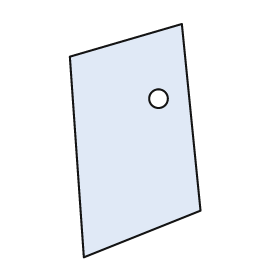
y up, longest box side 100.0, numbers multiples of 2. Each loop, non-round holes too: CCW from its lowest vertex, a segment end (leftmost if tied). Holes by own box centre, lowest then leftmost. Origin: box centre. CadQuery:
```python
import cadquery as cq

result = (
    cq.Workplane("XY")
    .moveTo(-22.0, -50.0)
    .lineTo(28.0, -30.0)
    .lineTo(20.0, 50.0)
    .lineTo(-28.0, 36.0)
    .close()
    .moveTo(10.0, 18.0)
    .circle(4.0)
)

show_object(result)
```